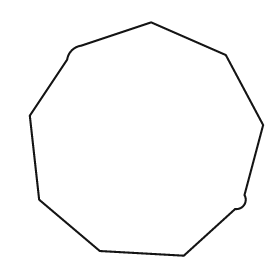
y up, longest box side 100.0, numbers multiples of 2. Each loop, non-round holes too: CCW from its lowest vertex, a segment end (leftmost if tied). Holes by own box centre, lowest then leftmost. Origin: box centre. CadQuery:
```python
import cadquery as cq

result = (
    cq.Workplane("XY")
    .moveTo(16.0, -50.0)
    .lineTo(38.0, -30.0)
    .threePointArc((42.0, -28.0), (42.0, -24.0))
    .lineTo(50.0, 6.0)
    .lineTo(34.0, 36.0)
    .lineTo(2.0, 50.0)
    .lineTo(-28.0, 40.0)
    .threePointArc((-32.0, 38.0), (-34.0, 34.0))
    .lineTo(-50.0, 10.0)
    .lineTo(-46.0, -26.0)
    .lineTo(-20.0, -48.0)
    .close()
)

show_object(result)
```